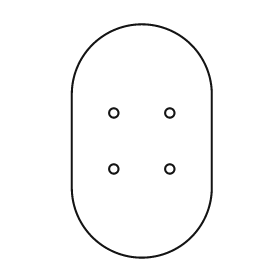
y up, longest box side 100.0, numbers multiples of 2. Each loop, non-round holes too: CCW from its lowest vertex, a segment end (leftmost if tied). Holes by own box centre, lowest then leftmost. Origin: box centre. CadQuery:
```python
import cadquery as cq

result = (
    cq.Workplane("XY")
    .moveTo(-30.0, -20.0)
    .threePointArc((0.0, -50.0), (30.0, -20.0))
    .lineTo(30.0, 20.0)
    .threePointArc((0.0, 50.0), (-30.0, 20.0))
    .close()
    .moveTo(-12.0, -12.0)
    .circle(2.0)
    .moveTo(12.0, -12.0)
    .circle(2.0)
    .moveTo(-12.0, 12.0)
    .circle(2.0)
    .moveTo(12.0, 12.0)
    .circle(2.0)
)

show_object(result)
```